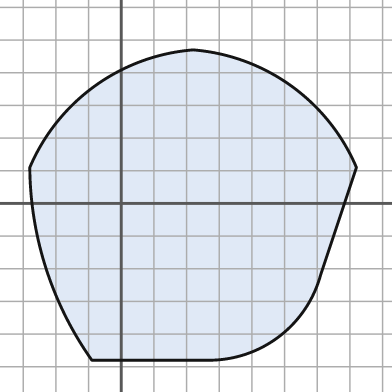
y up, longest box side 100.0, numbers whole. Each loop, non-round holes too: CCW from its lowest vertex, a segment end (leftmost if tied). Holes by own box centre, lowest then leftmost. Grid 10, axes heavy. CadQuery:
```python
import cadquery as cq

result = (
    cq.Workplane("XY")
    .moveTo(-9.0, -48.0)
    .lineTo(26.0, -48.0)
    .threePointArc((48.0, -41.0), (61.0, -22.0))
    .lineTo(72.0, 11.0)
    .threePointArc((52.0, 36.0), (22.0, 47.0))
    .threePointArc((-8.0, 36.0), (-28.0, 11.0))
    .threePointArc((-23.0, -20.0), (-9.0, -48.0))
    .close()
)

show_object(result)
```